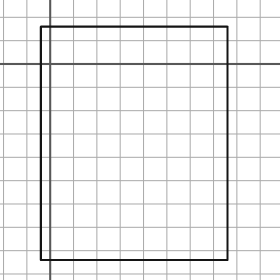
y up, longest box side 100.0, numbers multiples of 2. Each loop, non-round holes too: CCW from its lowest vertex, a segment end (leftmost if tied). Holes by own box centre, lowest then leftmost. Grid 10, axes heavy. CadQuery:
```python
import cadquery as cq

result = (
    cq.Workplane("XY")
    .moveTo(-4.0, -84.0)
    .lineTo(76.0, -84.0)
    .lineTo(76.0, 16.0)
    .lineTo(-4.0, 16.0)
    .close()
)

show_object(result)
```